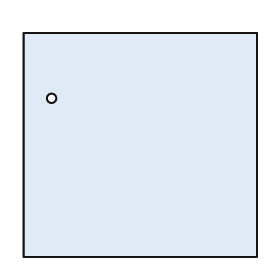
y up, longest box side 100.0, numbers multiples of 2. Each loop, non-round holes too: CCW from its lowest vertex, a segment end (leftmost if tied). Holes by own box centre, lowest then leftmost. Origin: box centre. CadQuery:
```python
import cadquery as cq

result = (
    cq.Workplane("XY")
    .moveTo(-50.0, -48.0)
    .lineTo(50.0, -48.0)
    .lineTo(50.0, 48.0)
    .lineTo(-50.0, 48.0)
    .close()
    .moveTo(-38.0, 20.0)
    .circle(2.0)
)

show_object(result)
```